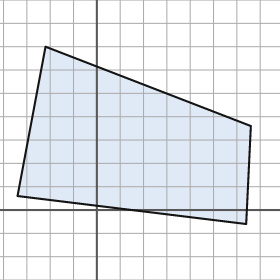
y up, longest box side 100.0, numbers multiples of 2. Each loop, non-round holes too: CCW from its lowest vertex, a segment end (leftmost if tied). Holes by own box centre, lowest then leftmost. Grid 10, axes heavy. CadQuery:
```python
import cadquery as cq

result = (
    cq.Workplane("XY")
    .moveTo(64.0, -6.0)
    .lineTo(66.0, 36.0)
    .lineTo(-22.0, 70.0)
    .lineTo(-34.0, 6.0)
    .close()
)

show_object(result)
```